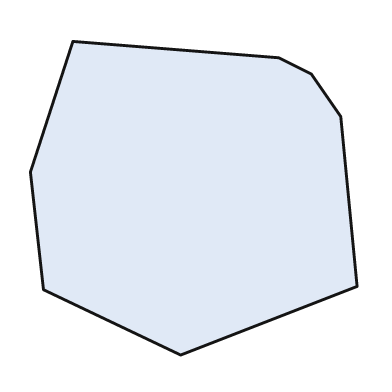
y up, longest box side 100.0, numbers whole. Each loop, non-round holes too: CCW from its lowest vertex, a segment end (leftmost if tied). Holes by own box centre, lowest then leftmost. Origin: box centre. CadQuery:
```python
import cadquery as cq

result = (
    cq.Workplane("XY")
    .moveTo(-4.0, -48.0)
    .lineTo(50.0, -27.0)
    .lineTo(45.0, 25.0)
    .lineTo(36.0, 38.0)
    .lineTo(26.0, 43.0)
    .lineTo(-37.0, 48.0)
    .lineTo(-50.0, 8.0)
    .lineTo(-46.0, -28.0)
    .close()
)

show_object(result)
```